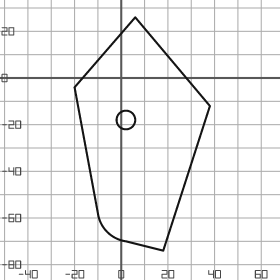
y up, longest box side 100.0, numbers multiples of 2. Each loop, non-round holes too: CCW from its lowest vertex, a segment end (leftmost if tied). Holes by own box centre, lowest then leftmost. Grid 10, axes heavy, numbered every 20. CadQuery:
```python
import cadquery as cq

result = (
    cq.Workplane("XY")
    .moveTo(18.0, -74.0)
    .lineTo(38.0, -12.0)
    .lineTo(6.0, 26.0)
    .lineTo(-20.0, -4.0)
    .lineTo(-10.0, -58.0)
    .threePointArc((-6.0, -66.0), (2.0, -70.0))
    .close()
    .moveTo(2.0, -18.0)
    .circle(4.0)
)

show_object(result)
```